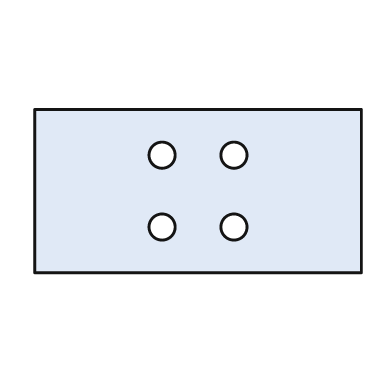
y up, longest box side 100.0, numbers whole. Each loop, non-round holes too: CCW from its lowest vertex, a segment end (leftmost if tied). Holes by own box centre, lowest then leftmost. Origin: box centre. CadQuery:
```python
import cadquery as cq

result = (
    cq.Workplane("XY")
    .moveTo(-50.0, -25.0)
    .lineTo(50.0, -25.0)
    .lineTo(50.0, 25.0)
    .lineTo(-50.0, 25.0)
    .close()
    .moveTo(-11.0, -11.0)
    .circle(4.0)
    .moveTo(11.0, -11.0)
    .circle(4.0)
    .moveTo(-11.0, 11.0)
    .circle(4.0)
    .moveTo(11.0, 11.0)
    .circle(4.0)
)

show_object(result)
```